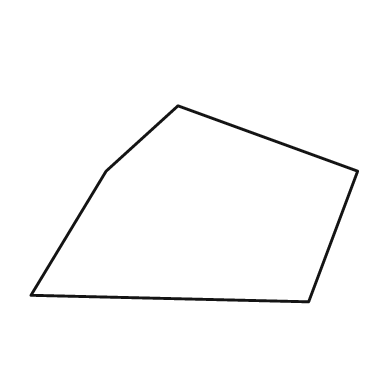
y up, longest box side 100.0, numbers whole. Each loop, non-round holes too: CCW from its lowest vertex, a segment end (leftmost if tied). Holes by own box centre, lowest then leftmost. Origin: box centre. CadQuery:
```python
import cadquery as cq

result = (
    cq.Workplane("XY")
    .moveTo(35.0, -30.0)
    .lineTo(50.0, 10.0)
    .lineTo(-5.0, 30.0)
    .lineTo(-27.0, 10.0)
    .lineTo(-50.0, -28.0)
    .close()
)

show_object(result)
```